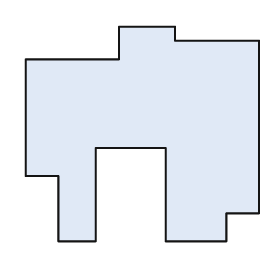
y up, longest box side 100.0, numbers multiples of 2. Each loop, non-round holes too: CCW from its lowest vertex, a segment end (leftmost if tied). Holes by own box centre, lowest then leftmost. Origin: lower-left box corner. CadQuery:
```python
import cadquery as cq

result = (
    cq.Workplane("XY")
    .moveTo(14.0, 0.0)
    .lineTo(30.0, 0.0)
    .lineTo(30.0, 40.0)
    .lineTo(60.0, 40.0)
    .lineTo(60.0, 0.0)
    .lineTo(86.0, 0.0)
    .lineTo(86.0, 12.0)
    .lineTo(100.0, 12.0)
    .lineTo(100.0, 86.0)
    .lineTo(64.0, 86.0)
    .lineTo(64.0, 92.0)
    .lineTo(40.0, 92.0)
    .lineTo(40.0, 78.0)
    .lineTo(0.0, 78.0)
    .lineTo(0.0, 28.0)
    .lineTo(14.0, 28.0)
    .close()
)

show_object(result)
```